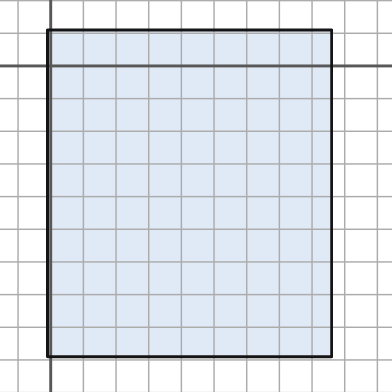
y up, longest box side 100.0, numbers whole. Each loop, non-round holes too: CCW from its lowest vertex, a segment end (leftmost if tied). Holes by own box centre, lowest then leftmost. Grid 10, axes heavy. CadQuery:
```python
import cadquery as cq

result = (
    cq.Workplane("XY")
    .moveTo(-1.0, -89.0)
    .lineTo(86.0, -89.0)
    .lineTo(86.0, 11.0)
    .lineTo(-1.0, 11.0)
    .close()
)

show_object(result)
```